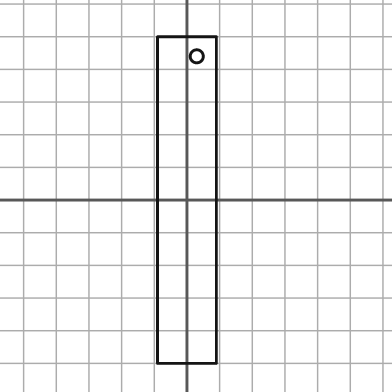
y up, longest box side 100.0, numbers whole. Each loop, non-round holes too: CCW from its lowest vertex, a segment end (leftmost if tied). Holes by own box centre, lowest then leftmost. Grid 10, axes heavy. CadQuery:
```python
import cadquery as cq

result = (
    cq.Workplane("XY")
    .moveTo(-9.0, -50.0)
    .lineTo(9.0, -50.0)
    .lineTo(9.0, 50.0)
    .lineTo(-9.0, 50.0)
    .close()
    .moveTo(3.0, 44.0)
    .circle(2.0)
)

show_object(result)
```